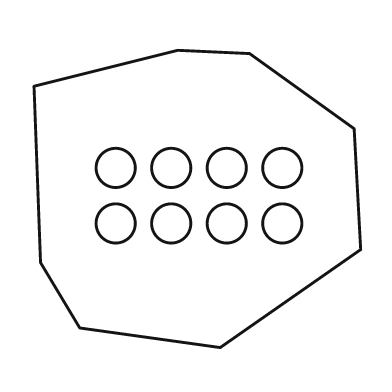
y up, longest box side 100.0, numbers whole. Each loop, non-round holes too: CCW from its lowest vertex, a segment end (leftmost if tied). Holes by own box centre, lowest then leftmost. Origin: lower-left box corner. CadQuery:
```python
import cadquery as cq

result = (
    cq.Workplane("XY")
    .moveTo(57.0, 0.0)
    .lineTo(100.0, 30.0)
    .lineTo(98.0, 67.0)
    .lineTo(66.0, 90.0)
    .lineTo(44.0, 91.0)
    .lineTo(0.0, 80.0)
    .lineTo(2.0, 26.0)
    .lineTo(14.0, 6.0)
    .close()
    .moveTo(25.0, 38.0)
    .circle(6.0)
    .moveTo(42.0, 38.0)
    .circle(6.0)
    .moveTo(59.0, 38.0)
    .circle(6.0)
    .moveTo(76.0, 38.0)
    .circle(6.0)
    .moveTo(25.0, 55.0)
    .circle(6.0)
    .moveTo(42.0, 55.0)
    .circle(6.0)
    .moveTo(59.0, 55.0)
    .circle(6.0)
    .moveTo(76.0, 55.0)
    .circle(6.0)
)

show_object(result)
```